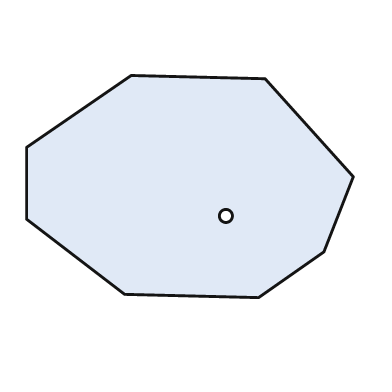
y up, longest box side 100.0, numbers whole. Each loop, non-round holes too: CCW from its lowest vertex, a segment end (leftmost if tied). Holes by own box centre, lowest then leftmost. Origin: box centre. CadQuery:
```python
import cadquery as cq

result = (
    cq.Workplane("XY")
    .moveTo(21.0, -34.0)
    .lineTo(41.0, -20.0)
    .lineTo(50.0, 3.0)
    .lineTo(23.0, 33.0)
    .lineTo(-18.0, 34.0)
    .lineTo(-50.0, 12.0)
    .lineTo(-50.0, -10.0)
    .lineTo(-20.0, -33.0)
    .close()
    .moveTo(11.0, -9.0)
    .circle(2.0)
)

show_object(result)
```